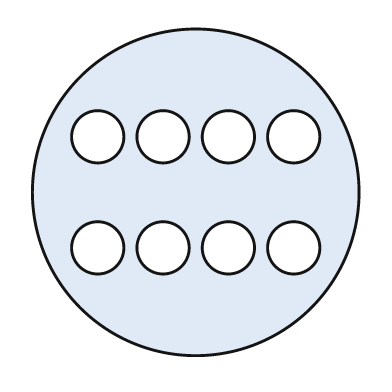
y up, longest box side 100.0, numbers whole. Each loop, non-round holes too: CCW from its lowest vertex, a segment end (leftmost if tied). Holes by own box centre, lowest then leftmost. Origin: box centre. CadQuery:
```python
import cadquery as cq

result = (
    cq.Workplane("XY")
    .moveTo(0.0, 0.0)
    .circle(50.0)
    .moveTo(-30.0, -17.0)
    .circle(8.0)
    .moveTo(-10.0, -17.0)
    .circle(8.0)
    .moveTo(10.0, -17.0)
    .circle(8.0)
    .moveTo(30.0, -17.0)
    .circle(8.0)
    .moveTo(-30.0, 17.0)
    .circle(8.0)
    .moveTo(-10.0, 17.0)
    .circle(8.0)
    .moveTo(10.0, 17.0)
    .circle(8.0)
    .moveTo(30.0, 17.0)
    .circle(8.0)
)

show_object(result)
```